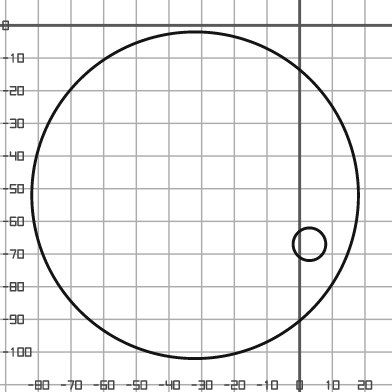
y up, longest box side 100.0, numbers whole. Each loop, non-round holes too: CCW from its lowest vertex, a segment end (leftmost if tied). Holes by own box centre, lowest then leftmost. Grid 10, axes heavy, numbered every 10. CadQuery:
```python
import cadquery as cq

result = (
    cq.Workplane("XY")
    .moveTo(-32.0, -52.0)
    .circle(50.0)
    .moveTo(3.0, -67.0)
    .circle(5.0)
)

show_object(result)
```